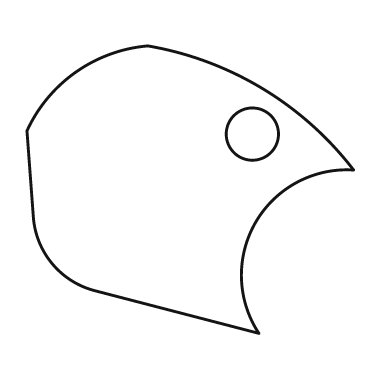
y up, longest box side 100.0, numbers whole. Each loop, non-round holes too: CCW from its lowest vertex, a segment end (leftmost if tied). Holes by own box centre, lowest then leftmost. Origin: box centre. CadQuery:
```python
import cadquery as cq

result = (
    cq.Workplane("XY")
    .moveTo(21.0, -44.0)
    .threePointArc((20.0, -10.0), (50.0, 6.0))
    .threePointArc((22.0, 31.0), (-13.0, 44.0))
    .threePointArc((-35.0, 36.0), (-50.0, 18.0))
    .lineTo(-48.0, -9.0)
    .threePointArc((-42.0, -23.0), (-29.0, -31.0))
    .close()
    .moveTo(19.0, 17.0)
    .circle(8.0)
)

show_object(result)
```